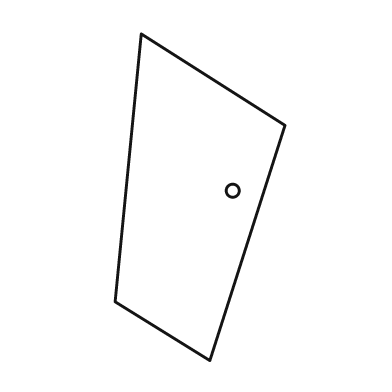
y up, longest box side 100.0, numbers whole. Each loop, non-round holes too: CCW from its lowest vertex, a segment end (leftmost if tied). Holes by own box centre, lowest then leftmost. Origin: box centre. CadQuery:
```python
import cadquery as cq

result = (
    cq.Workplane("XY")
    .moveTo(3.0, -50.0)
    .lineTo(26.0, 22.0)
    .lineTo(-18.0, 50.0)
    .lineTo(-26.0, -32.0)
    .close()
    .moveTo(10.0, 2.0)
    .circle(2.0)
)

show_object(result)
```